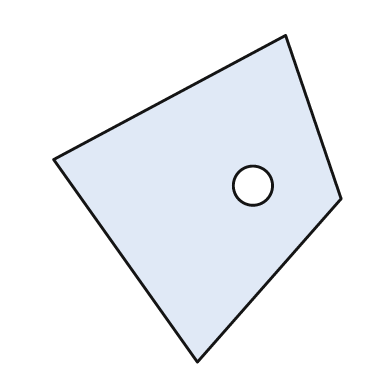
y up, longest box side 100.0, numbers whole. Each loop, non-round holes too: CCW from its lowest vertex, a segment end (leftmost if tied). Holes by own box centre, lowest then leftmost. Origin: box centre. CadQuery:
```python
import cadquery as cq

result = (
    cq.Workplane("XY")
    .moveTo(0.0, -50.0)
    .lineTo(44.0, 0.0)
    .lineTo(27.0, 50.0)
    .lineTo(-44.0, 12.0)
    .close()
    .moveTo(17.0, 4.0)
    .circle(6.0)
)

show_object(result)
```